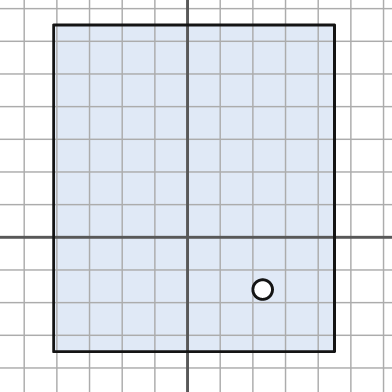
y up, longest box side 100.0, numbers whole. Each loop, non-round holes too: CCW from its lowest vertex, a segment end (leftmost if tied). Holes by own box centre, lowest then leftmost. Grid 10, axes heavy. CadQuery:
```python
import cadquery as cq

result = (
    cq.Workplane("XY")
    .moveTo(-41.0, -35.0)
    .lineTo(45.0, -35.0)
    .lineTo(45.0, 65.0)
    .lineTo(-41.0, 65.0)
    .close()
    .moveTo(23.0, -16.0)
    .circle(3.0)
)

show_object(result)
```